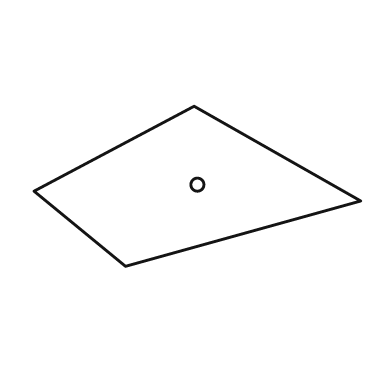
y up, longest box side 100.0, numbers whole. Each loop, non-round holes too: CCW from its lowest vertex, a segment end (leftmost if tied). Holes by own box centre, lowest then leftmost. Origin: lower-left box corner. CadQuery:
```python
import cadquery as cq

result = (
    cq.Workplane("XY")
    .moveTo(28.0, 0.0)
    .lineTo(100.0, 20.0)
    .lineTo(49.0, 49.0)
    .lineTo(0.0, 23.0)
    .close()
    .moveTo(50.0, 25.0)
    .circle(2.0)
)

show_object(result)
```